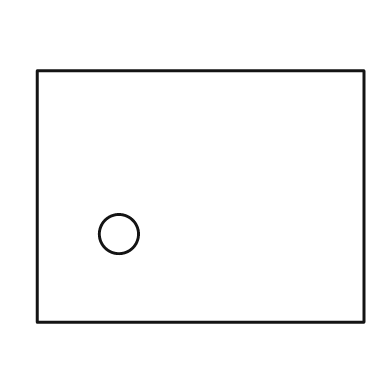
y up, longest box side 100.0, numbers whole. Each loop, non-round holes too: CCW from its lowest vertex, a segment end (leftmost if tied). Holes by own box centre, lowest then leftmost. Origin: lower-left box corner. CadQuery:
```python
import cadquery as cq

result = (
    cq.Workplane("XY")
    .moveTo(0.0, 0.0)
    .lineTo(100.0, 0.0)
    .lineTo(100.0, 77.0)
    .lineTo(0.0, 77.0)
    .close()
    .moveTo(25.0, 27.0)
    .circle(6.0)
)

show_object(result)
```